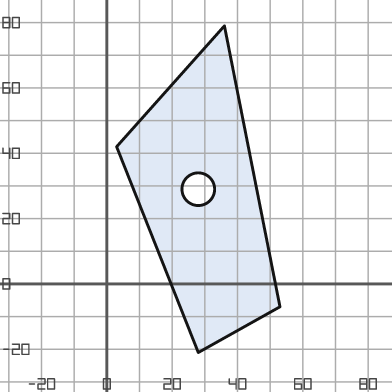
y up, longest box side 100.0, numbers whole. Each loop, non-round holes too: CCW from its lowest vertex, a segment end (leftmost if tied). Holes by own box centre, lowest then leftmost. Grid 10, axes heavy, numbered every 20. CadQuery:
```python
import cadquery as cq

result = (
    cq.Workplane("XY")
    .moveTo(28.0, -21.0)
    .lineTo(53.0, -7.0)
    .lineTo(36.0, 79.0)
    .lineTo(3.0, 42.0)
    .close()
    .moveTo(28.0, 29.0)
    .circle(5.0)
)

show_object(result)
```